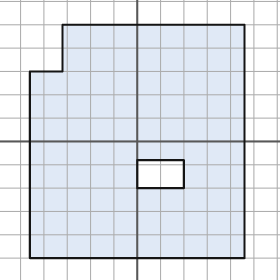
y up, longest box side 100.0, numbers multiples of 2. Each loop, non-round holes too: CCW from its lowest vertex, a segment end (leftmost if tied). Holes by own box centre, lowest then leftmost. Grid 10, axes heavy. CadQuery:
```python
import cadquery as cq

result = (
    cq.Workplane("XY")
    .moveTo(-46.0, -50.0)
    .lineTo(46.0, -50.0)
    .lineTo(46.0, 50.0)
    .lineTo(-32.0, 50.0)
    .lineTo(-32.0, 30.0)
    .lineTo(-46.0, 30.0)
    .close()
    .moveTo(0.0, -20.0)
    .lineTo(20.0, -20.0)
    .lineTo(20.0, -8.0)
    .lineTo(0.0, -8.0)
    .close()
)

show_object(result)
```